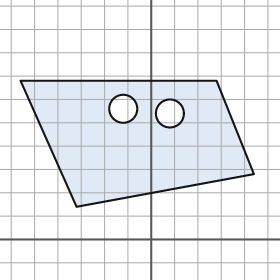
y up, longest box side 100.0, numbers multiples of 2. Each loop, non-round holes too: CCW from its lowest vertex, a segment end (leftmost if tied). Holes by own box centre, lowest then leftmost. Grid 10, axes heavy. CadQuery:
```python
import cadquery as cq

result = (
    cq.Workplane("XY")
    .moveTo(-32.0, 14.0)
    .lineTo(44.0, 28.0)
    .lineTo(28.0, 68.0)
    .lineTo(-56.0, 68.0)
    .close()
    .moveTo(8.0, 54.0)
    .circle(6.0)
    .moveTo(-12.0, 56.0)
    .circle(6.0)
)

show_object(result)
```